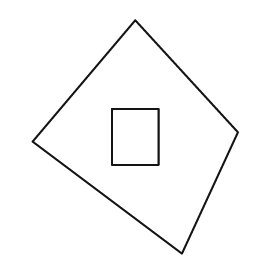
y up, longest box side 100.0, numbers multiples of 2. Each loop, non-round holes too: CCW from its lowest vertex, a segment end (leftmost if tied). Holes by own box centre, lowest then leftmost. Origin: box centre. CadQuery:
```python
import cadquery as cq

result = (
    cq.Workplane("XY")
    .moveTo(20.0, -50.0)
    .lineTo(44.0, 2.0)
    .lineTo(0.0, 50.0)
    .lineTo(-44.0, -2.0)
    .close()
    .moveTo(-10.0, -12.0)
    .lineTo(10.0, -12.0)
    .lineTo(10.0, 12.0)
    .lineTo(-10.0, 12.0)
    .close()
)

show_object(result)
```